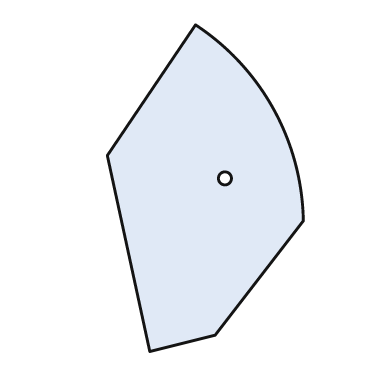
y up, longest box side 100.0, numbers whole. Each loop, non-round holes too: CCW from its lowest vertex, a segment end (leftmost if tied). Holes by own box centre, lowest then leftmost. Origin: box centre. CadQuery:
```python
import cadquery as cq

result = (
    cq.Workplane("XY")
    .moveTo(-17.0, -50.0)
    .lineTo(3.0, -45.0)
    .lineTo(30.0, -10.0)
    .threePointArc((21.0, 24.0), (-3.0, 50.0))
    .lineTo(-30.0, 10.0)
    .close()
    .moveTo(6.0, 3.0)
    .circle(2.0)
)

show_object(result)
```